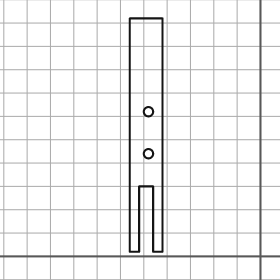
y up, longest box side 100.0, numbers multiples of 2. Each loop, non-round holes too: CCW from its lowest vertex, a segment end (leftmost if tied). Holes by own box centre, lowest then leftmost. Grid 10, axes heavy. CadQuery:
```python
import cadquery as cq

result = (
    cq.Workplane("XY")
    .moveTo(-56.0, 2.0)
    .lineTo(-52.0, 2.0)
    .lineTo(-52.0, 30.0)
    .lineTo(-46.0, 30.0)
    .lineTo(-46.0, 2.0)
    .lineTo(-42.0, 2.0)
    .lineTo(-42.0, 102.0)
    .lineTo(-56.0, 102.0)
    .close()
    .moveTo(-48.0, 44.0)
    .circle(2.0)
    .moveTo(-48.0, 62.0)
    .circle(2.0)
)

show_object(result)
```